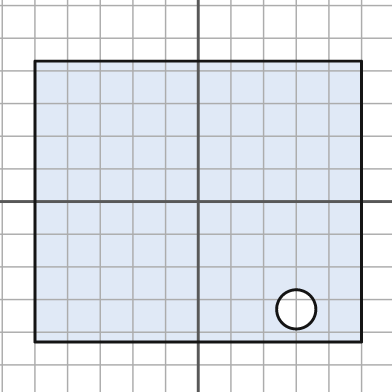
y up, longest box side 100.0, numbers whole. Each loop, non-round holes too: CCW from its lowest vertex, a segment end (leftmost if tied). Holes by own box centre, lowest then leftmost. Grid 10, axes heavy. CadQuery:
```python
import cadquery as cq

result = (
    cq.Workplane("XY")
    .moveTo(-50.0, -43.0)
    .lineTo(50.0, -43.0)
    .lineTo(50.0, 43.0)
    .lineTo(-50.0, 43.0)
    .close()
    .moveTo(30.0, -33.0)
    .circle(6.0)
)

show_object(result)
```